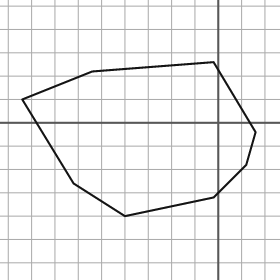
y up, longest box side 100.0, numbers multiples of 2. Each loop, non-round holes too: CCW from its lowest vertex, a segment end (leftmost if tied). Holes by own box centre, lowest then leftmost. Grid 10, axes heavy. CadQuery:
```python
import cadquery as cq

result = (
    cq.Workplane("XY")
    .moveTo(-40.0, -40.0)
    .lineTo(-2.0, -32.0)
    .lineTo(12.0, -18.0)
    .lineTo(16.0, -4.0)
    .lineTo(-2.0, 26.0)
    .lineTo(-54.0, 22.0)
    .lineTo(-84.0, 10.0)
    .lineTo(-62.0, -26.0)
    .close()
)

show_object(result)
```